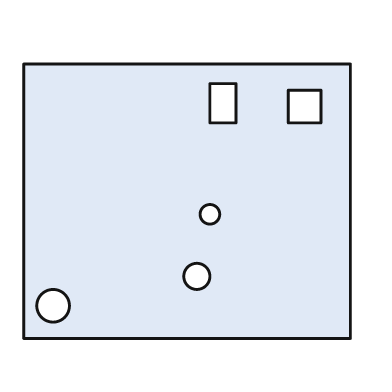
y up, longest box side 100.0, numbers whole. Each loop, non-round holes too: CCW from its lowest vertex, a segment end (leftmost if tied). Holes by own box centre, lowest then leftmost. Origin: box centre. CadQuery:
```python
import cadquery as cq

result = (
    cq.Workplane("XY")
    .moveTo(-50.0, -42.0)
    .lineTo(50.0, -42.0)
    .lineTo(50.0, 42.0)
    .lineTo(-50.0, 42.0)
    .close()
    .moveTo(-41.0, -32.0)
    .circle(5.0)
    .moveTo(3.0, -23.0)
    .circle(4.0)
    .moveTo(7.0, -4.0)
    .circle(3.0)
    .moveTo(31.0, 24.0)
    .lineTo(41.0, 24.0)
    .lineTo(41.0, 34.0)
    .lineTo(31.0, 34.0)
    .close()
    .moveTo(7.0, 24.0)
    .lineTo(15.0, 24.0)
    .lineTo(15.0, 36.0)
    .lineTo(7.0, 36.0)
    .close()
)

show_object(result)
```